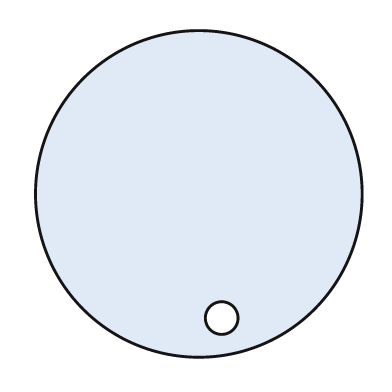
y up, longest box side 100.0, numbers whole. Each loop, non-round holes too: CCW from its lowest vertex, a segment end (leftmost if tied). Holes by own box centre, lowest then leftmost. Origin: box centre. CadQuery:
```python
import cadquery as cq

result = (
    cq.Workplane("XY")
    .moveTo(0.0, 0.0)
    .circle(50.0)
    .moveTo(7.0, -38.0)
    .circle(5.0)
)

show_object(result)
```